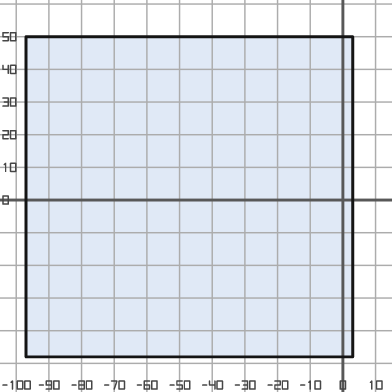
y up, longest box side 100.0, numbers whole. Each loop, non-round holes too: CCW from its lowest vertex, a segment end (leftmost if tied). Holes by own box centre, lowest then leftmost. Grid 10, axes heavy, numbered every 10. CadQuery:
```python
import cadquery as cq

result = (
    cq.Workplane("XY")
    .moveTo(-97.0, -48.0)
    .lineTo(3.0, -48.0)
    .lineTo(3.0, 50.0)
    .lineTo(-97.0, 50.0)
    .close()
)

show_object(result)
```